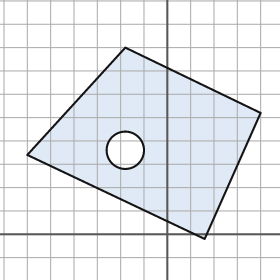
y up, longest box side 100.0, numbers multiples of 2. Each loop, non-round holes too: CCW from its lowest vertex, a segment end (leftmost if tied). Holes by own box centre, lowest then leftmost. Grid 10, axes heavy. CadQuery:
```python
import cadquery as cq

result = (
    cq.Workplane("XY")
    .moveTo(16.0, -2.0)
    .lineTo(40.0, 52.0)
    .lineTo(-18.0, 80.0)
    .lineTo(-60.0, 34.0)
    .close()
    .moveTo(-18.0, 36.0)
    .circle(8.0)
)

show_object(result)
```